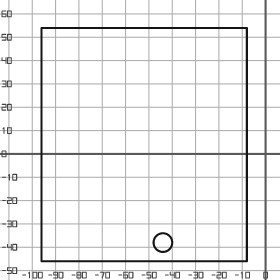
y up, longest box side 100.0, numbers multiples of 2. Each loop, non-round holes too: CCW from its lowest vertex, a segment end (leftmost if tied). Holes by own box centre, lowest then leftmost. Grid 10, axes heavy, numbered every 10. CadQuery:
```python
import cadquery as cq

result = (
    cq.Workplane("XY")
    .moveTo(-96.0, -46.0)
    .lineTo(-8.0, -46.0)
    .lineTo(-8.0, 54.0)
    .lineTo(-96.0, 54.0)
    .close()
    .moveTo(-44.0, -38.0)
    .circle(4.0)
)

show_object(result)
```